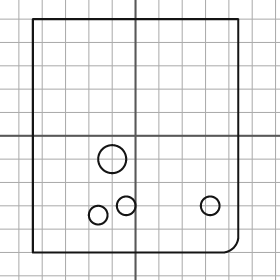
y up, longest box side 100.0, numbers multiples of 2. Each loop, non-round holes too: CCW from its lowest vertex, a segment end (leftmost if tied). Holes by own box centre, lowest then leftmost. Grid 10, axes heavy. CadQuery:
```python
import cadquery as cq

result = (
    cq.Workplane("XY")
    .moveTo(-44.0, -50.0)
    .lineTo(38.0, -50.0)
    .threePointArc((42.0, -48.0), (44.0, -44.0))
    .lineTo(44.0, 50.0)
    .lineTo(-44.0, 50.0)
    .close()
    .moveTo(-16.0, -34.0)
    .circle(4.0)
    .moveTo(-4.0, -30.0)
    .circle(4.0)
    .moveTo(32.0, -30.0)
    .circle(4.0)
    .moveTo(-10.0, -10.0)
    .circle(6.0)
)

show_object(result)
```